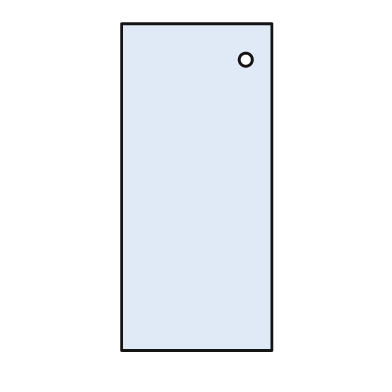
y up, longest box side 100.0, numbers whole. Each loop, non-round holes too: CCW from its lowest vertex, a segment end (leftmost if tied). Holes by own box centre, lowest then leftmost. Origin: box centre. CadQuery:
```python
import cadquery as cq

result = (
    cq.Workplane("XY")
    .moveTo(-23.0, -50.0)
    .lineTo(23.0, -50.0)
    .lineTo(23.0, 50.0)
    .lineTo(-23.0, 50.0)
    .close()
    .moveTo(15.0, 39.0)
    .circle(2.0)
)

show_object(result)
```